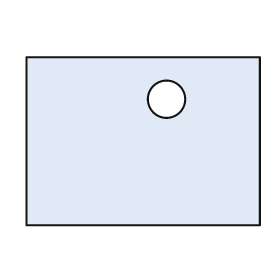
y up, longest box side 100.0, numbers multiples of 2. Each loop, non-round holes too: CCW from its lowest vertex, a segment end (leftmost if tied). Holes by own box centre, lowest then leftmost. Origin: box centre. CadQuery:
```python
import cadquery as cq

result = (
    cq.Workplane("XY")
    .moveTo(-50.0, -36.0)
    .lineTo(50.0, -36.0)
    .lineTo(50.0, 36.0)
    .lineTo(-50.0, 36.0)
    .close()
    .moveTo(10.0, 18.0)
    .circle(8.0)
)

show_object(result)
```